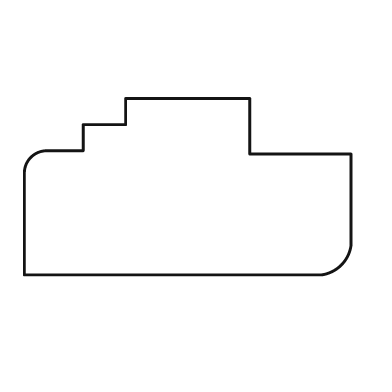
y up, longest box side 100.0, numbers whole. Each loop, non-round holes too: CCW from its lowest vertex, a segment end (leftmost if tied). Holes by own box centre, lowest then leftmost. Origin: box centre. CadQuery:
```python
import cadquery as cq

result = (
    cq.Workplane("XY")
    .moveTo(-50.0, -27.0)
    .lineTo(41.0, -27.0)
    .threePointArc((47.0, -24.0), (50.0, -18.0))
    .lineTo(50.0, 10.0)
    .lineTo(19.0, 10.0)
    .lineTo(19.0, 27.0)
    .lineTo(-19.0, 27.0)
    .lineTo(-19.0, 19.0)
    .lineTo(-32.0, 19.0)
    .lineTo(-32.0, 11.0)
    .lineTo(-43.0, 11.0)
    .threePointArc((-48.0, 9.0), (-50.0, 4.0))
    .close()
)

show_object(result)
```